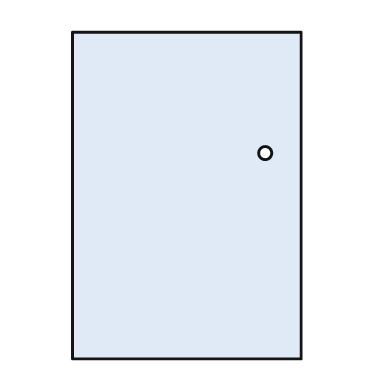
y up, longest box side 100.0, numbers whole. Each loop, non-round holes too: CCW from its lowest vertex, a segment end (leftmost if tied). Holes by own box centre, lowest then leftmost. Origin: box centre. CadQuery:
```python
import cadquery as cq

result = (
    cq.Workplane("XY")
    .moveTo(-35.0, -50.0)
    .lineTo(35.0, -50.0)
    .lineTo(35.0, 50.0)
    .lineTo(-35.0, 50.0)
    .close()
    .moveTo(24.0, 13.0)
    .circle(2.0)
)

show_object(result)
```